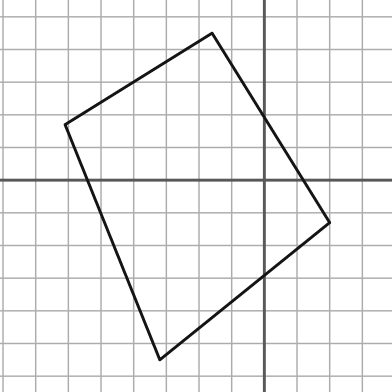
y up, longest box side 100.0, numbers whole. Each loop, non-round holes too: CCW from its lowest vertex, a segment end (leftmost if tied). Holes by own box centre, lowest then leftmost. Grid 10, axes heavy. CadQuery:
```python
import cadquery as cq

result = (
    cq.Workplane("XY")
    .moveTo(-32.0, -55.0)
    .lineTo(20.0, -13.0)
    .lineTo(-16.0, 45.0)
    .lineTo(-61.0, 17.0)
    .close()
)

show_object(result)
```